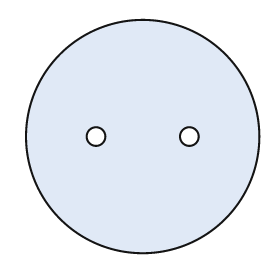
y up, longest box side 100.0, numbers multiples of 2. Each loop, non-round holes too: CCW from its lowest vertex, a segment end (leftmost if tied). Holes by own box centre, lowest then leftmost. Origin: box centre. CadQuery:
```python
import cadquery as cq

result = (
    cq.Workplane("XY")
    .moveTo(0.0, 0.0)
    .circle(50.0)
    .moveTo(-20.0, 0.0)
    .circle(4.0)
    .moveTo(20.0, 0.0)
    .circle(4.0)
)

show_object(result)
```